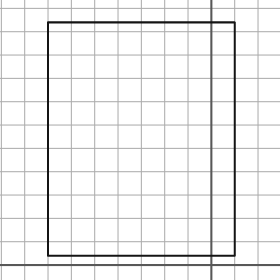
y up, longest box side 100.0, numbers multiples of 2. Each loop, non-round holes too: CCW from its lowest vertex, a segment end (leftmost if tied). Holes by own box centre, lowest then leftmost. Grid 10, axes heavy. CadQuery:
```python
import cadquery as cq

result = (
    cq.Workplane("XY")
    .moveTo(-70.0, 4.0)
    .lineTo(10.0, 4.0)
    .lineTo(10.0, 104.0)
    .lineTo(-70.0, 104.0)
    .close()
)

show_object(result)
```